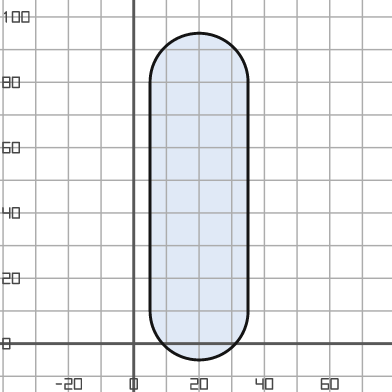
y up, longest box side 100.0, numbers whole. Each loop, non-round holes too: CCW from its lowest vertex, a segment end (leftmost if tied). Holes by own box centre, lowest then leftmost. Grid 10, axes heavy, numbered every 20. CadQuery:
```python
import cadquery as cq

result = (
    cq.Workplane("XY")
    .moveTo(5.0, 10.0)
    .threePointArc((20.0, -5.0), (35.0, 10.0))
    .lineTo(35.0, 80.0)
    .threePointArc((20.0, 95.0), (5.0, 80.0))
    .close()
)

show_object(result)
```